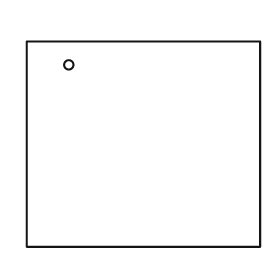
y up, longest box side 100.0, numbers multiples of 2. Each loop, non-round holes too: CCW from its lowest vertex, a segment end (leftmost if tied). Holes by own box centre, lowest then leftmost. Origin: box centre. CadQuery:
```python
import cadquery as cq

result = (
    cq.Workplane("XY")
    .moveTo(-50.0, -44.0)
    .lineTo(50.0, -44.0)
    .lineTo(50.0, 44.0)
    .lineTo(-50.0, 44.0)
    .close()
    .moveTo(-32.0, 34.0)
    .circle(2.0)
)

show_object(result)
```